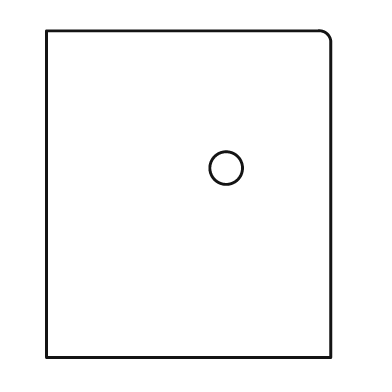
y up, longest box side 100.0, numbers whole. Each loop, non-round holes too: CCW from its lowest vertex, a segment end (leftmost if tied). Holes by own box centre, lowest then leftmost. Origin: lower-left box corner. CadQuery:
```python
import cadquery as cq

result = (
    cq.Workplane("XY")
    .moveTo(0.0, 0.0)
    .lineTo(87.0, 0.0)
    .lineTo(87.0, 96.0)
    .threePointArc((86.0, 99.0), (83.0, 100.0))
    .lineTo(0.0, 100.0)
    .close()
    .moveTo(55.0, 58.0)
    .circle(5.0)
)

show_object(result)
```